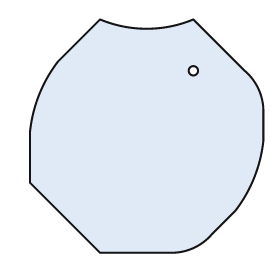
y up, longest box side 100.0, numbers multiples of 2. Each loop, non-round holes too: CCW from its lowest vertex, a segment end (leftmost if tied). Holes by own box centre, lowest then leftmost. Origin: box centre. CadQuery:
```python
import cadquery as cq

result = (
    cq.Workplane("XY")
    .moveTo(-20.0, -50.0)
    .lineTo(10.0, -50.0)
    .threePointArc((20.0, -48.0), (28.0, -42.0))
    .lineTo(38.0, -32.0)
    .threePointArc((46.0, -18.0), (50.0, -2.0))
    .lineTo(50.0, 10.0)
    .threePointArc((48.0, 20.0), (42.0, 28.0))
    .lineTo(20.0, 50.0)
    .threePointArc((0.0, 46.0), (-20.0, 50.0))
    .lineTo(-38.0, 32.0)
    .threePointArc((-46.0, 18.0), (-50.0, 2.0))
    .lineTo(-50.0, -20.0)
    .close()
    .moveTo(20.0, 28.0)
    .circle(2.0)
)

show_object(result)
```